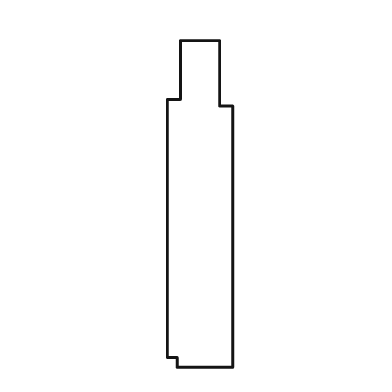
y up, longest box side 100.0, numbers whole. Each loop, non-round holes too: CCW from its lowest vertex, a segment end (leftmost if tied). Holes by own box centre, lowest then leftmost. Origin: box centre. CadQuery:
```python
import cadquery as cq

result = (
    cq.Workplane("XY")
    .moveTo(-7.0, -50.0)
    .lineTo(10.0, -50.0)
    .lineTo(10.0, 30.0)
    .lineTo(6.0, 30.0)
    .lineTo(6.0, 50.0)
    .lineTo(-6.0, 50.0)
    .lineTo(-6.0, 32.0)
    .lineTo(-10.0, 32.0)
    .lineTo(-10.0, -47.0)
    .lineTo(-7.0, -47.0)
    .close()
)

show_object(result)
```